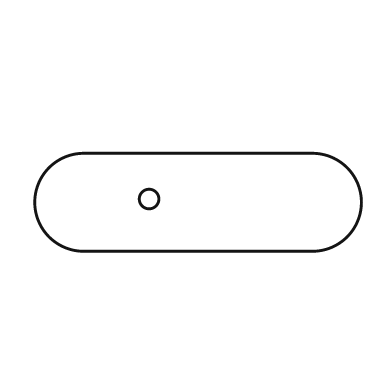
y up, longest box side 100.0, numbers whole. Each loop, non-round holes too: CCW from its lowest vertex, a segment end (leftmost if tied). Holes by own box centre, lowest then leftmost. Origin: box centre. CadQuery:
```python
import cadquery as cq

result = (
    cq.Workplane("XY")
    .moveTo(-35.0, -15.0)
    .lineTo(35.0, -15.0)
    .threePointArc((50.0, 0.0), (35.0, 15.0))
    .lineTo(-35.0, 15.0)
    .threePointArc((-50.0, 0.0), (-35.0, -15.0))
    .close()
    .moveTo(-15.0, 1.0)
    .circle(3.0)
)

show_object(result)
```